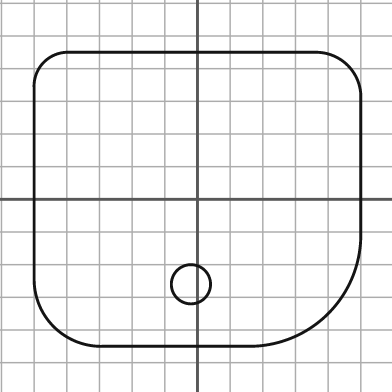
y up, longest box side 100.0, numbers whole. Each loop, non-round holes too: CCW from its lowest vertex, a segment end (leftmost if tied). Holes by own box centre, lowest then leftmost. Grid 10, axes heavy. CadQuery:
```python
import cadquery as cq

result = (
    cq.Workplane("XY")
    .moveTo(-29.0, -45.0)
    .lineTo(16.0, -45.0)
    .threePointArc((40.0, -35.0), (50.0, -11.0))
    .lineTo(50.0, 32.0)
    .threePointArc((46.0, 41.0), (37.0, 45.0))
    .lineTo(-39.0, 45.0)
    .threePointArc((-47.0, 42.0), (-50.0, 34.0))
    .lineTo(-50.0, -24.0)
    .threePointArc((-44.0, -39.0), (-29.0, -45.0))
    .close()
    .moveTo(-2.0, -26.0)
    .circle(6.0)
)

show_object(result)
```